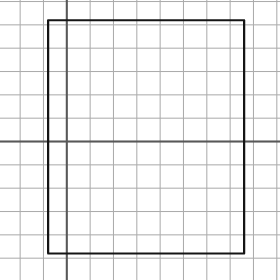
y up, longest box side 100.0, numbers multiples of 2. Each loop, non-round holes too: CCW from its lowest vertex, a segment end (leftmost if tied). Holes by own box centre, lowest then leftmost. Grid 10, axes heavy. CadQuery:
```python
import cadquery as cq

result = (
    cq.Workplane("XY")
    .moveTo(-8.0, -48.0)
    .lineTo(76.0, -48.0)
    .lineTo(76.0, 52.0)
    .lineTo(-8.0, 52.0)
    .close()
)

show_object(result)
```